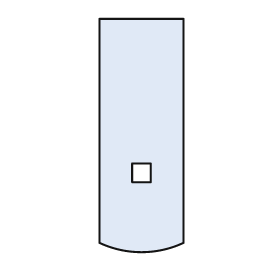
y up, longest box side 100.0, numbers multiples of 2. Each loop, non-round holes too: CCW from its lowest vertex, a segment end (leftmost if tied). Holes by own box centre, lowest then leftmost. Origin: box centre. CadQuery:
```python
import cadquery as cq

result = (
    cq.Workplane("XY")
    .moveTo(-18.0, -46.0)
    .threePointArc((0.0, -50.0), (18.0, -46.0))
    .lineTo(18.0, 50.0)
    .lineTo(-18.0, 50.0)
    .close()
    .moveTo(-4.0, -20.0)
    .lineTo(4.0, -20.0)
    .lineTo(4.0, -12.0)
    .lineTo(-4.0, -12.0)
    .close()
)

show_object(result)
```